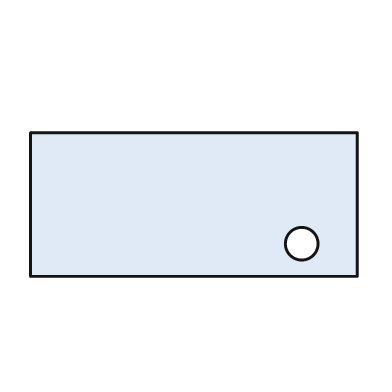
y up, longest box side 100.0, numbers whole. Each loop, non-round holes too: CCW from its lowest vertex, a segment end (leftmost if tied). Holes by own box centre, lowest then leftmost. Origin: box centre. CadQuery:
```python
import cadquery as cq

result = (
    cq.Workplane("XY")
    .moveTo(-50.0, -22.0)
    .lineTo(50.0, -22.0)
    .lineTo(50.0, 22.0)
    .lineTo(-50.0, 22.0)
    .close()
    .moveTo(33.0, -12.0)
    .circle(5.0)
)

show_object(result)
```